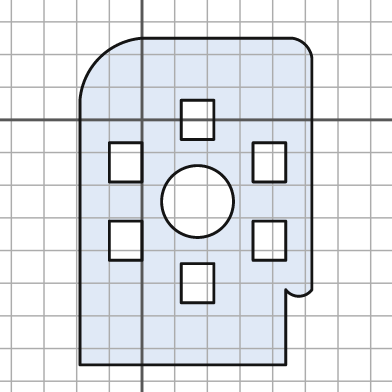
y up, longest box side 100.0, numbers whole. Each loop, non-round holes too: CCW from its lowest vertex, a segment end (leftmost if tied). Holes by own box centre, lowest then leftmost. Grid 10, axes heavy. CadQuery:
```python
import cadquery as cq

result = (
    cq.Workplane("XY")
    .moveTo(-19.0, -75.0)
    .lineTo(44.0, -75.0)
    .lineTo(44.0, -52.0)
    .threePointArc((48.0, -54.0), (52.0, -52.0))
    .lineTo(52.0, 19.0)
    .threePointArc((50.0, 23.0), (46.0, 25.0))
    .lineTo(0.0, 25.0)
    .threePointArc((-13.0, 19.0), (-19.0, 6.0))
    .close()
    .moveTo(12.0, -56.0)
    .lineTo(22.0, -56.0)
    .lineTo(22.0, -44.0)
    .lineTo(12.0, -44.0)
    .close()
    .moveTo(-10.0, -43.0)
    .lineTo(0.0, -43.0)
    .lineTo(0.0, -31.0)
    .lineTo(-10.0, -31.0)
    .close()
    .moveTo(34.0, -43.0)
    .lineTo(44.0, -43.0)
    .lineTo(44.0, -31.0)
    .lineTo(34.0, -31.0)
    .close()
    .moveTo(17.0, -25.0)
    .circle(11.0)
    .moveTo(-10.0, -19.0)
    .lineTo(0.0, -19.0)
    .lineTo(0.0, -7.0)
    .lineTo(-10.0, -7.0)
    .close()
    .moveTo(34.0, -19.0)
    .lineTo(44.0, -19.0)
    .lineTo(44.0, -7.0)
    .lineTo(34.0, -7.0)
    .close()
    .moveTo(12.0, -6.0)
    .lineTo(22.0, -6.0)
    .lineTo(22.0, 6.0)
    .lineTo(12.0, 6.0)
    .close()
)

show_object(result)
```